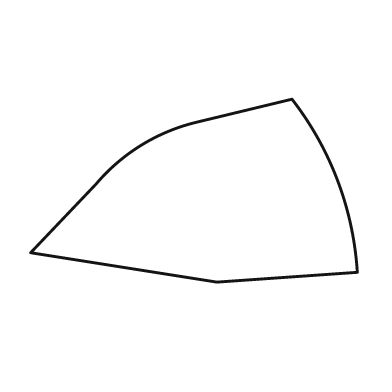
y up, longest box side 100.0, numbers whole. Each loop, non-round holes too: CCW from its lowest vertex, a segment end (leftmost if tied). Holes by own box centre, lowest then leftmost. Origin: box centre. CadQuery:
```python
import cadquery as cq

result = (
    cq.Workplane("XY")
    .moveTo(7.0, -28.0)
    .lineTo(50.0, -25.0)
    .threePointArc((44.0, 3.0), (30.0, 28.0))
    .lineTo(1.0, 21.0)
    .threePointArc((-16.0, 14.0), (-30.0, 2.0))
    .lineTo(-50.0, -19.0)
    .close()
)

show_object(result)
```